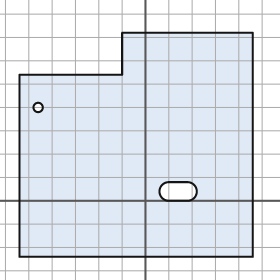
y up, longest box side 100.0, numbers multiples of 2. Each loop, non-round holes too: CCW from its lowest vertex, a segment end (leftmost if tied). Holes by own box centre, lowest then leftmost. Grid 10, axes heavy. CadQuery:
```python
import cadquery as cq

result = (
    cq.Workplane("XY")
    .moveTo(-54.0, -24.0)
    .lineTo(46.0, -24.0)
    .lineTo(46.0, 72.0)
    .lineTo(-10.0, 72.0)
    .lineTo(-10.0, 54.0)
    .lineTo(-54.0, 54.0)
    .close()
    .moveTo(10.0, 0.0)
    .lineTo(18.0, 0.0)
    .threePointArc((22.0, 4.0), (18.0, 8.0))
    .lineTo(10.0, 8.0)
    .threePointArc((6.0, 4.0), (10.0, 0.0))
    .close()
    .moveTo(-46.0, 40.0)
    .circle(2.0)
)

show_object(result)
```